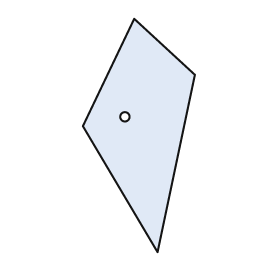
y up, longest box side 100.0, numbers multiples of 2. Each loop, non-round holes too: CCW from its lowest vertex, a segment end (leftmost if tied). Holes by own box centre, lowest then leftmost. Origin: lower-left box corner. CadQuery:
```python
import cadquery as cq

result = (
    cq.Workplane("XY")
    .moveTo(32.0, 0.0)
    .lineTo(48.0, 76.0)
    .lineTo(22.0, 100.0)
    .lineTo(0.0, 54.0)
    .close()
    .moveTo(18.0, 58.0)
    .circle(2.0)
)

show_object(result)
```